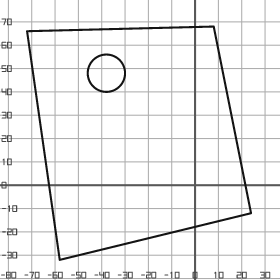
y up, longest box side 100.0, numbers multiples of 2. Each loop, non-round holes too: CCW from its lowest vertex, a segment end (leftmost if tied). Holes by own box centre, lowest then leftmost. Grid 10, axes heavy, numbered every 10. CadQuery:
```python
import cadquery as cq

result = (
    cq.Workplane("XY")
    .moveTo(-58.0, -32.0)
    .lineTo(24.0, -12.0)
    .lineTo(8.0, 68.0)
    .lineTo(-72.0, 66.0)
    .close()
    .moveTo(-38.0, 48.0)
    .circle(8.0)
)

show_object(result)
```